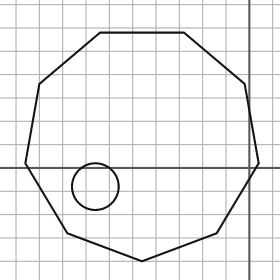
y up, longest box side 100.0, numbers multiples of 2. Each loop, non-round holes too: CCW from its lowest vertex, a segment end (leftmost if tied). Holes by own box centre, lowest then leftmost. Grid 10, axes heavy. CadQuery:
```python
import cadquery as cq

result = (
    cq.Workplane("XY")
    .moveTo(-46.0, -40.0)
    .lineTo(-14.0, -28.0)
    .lineTo(4.0, 2.0)
    .lineTo(-2.0, 36.0)
    .lineTo(-28.0, 58.0)
    .lineTo(-64.0, 58.0)
    .lineTo(-90.0, 36.0)
    .lineTo(-96.0, 2.0)
    .lineTo(-78.0, -28.0)
    .close()
    .moveTo(-66.0, -8.0)
    .circle(10.0)
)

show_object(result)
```